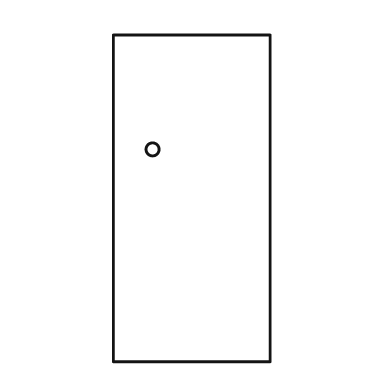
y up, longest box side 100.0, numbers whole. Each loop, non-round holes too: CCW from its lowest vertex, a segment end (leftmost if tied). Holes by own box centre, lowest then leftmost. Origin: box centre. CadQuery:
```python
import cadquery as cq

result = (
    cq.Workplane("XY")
    .moveTo(-24.0, -50.0)
    .lineTo(24.0, -50.0)
    .lineTo(24.0, 50.0)
    .lineTo(-24.0, 50.0)
    .close()
    .moveTo(-12.0, 15.0)
    .circle(2.0)
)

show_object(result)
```